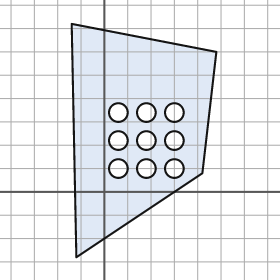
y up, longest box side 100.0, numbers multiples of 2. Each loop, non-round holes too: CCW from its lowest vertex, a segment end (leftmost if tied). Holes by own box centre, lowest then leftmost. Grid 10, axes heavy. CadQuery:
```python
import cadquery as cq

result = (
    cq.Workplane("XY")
    .moveTo(-12.0, -28.0)
    .lineTo(42.0, 8.0)
    .lineTo(48.0, 60.0)
    .lineTo(-14.0, 72.0)
    .close()
    .moveTo(6.0, 10.0)
    .circle(4.0)
    .moveTo(18.0, 10.0)
    .circle(4.0)
    .moveTo(30.0, 10.0)
    .circle(4.0)
    .moveTo(6.0, 22.0)
    .circle(4.0)
    .moveTo(18.0, 22.0)
    .circle(4.0)
    .moveTo(30.0, 22.0)
    .circle(4.0)
    .moveTo(6.0, 34.0)
    .circle(4.0)
    .moveTo(18.0, 34.0)
    .circle(4.0)
    .moveTo(30.0, 34.0)
    .circle(4.0)
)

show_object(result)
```